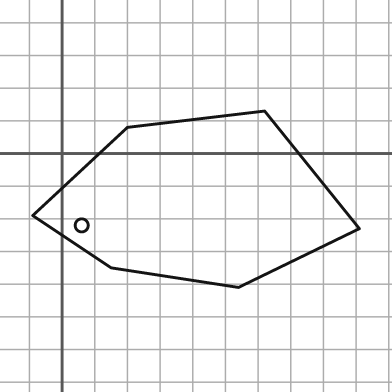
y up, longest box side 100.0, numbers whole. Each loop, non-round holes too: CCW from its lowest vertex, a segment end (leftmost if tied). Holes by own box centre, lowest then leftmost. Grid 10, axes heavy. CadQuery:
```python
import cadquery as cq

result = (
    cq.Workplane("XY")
    .moveTo(54.0, -41.0)
    .lineTo(91.0, -23.0)
    .lineTo(62.0, 13.0)
    .lineTo(20.0, 8.0)
    .lineTo(-9.0, -19.0)
    .lineTo(15.0, -35.0)
    .close()
    .moveTo(6.0, -22.0)
    .circle(2.0)
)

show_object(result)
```